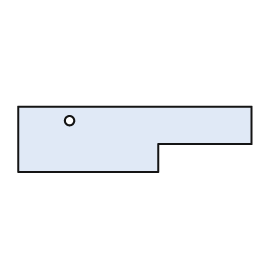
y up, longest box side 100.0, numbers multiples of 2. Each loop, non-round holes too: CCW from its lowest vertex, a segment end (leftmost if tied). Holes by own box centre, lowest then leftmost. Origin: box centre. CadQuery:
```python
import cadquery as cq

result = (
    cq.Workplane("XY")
    .moveTo(-50.0, -14.0)
    .lineTo(10.0, -14.0)
    .lineTo(10.0, -2.0)
    .lineTo(50.0, -2.0)
    .lineTo(50.0, 14.0)
    .lineTo(-50.0, 14.0)
    .close()
    .moveTo(-28.0, 8.0)
    .circle(2.0)
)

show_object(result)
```